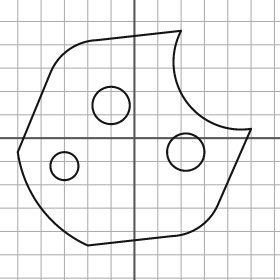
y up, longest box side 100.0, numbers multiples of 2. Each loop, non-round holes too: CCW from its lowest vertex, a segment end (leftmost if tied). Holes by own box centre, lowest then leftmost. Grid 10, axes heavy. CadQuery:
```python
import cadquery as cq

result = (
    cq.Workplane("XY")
    .moveTo(-20.0, -46.0)
    .lineTo(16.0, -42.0)
    .threePointArc((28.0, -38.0), (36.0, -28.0))
    .lineTo(50.0, 4.0)
    .threePointArc((22.0, 16.0), (20.0, 46.0))
    .lineTo(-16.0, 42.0)
    .threePointArc((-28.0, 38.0), (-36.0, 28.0))
    .lineTo(-50.0, -6.0)
    .threePointArc((-40.0, -30.0), (-20.0, -46.0))
    .close()
    .moveTo(-30.0, -12.0)
    .circle(6.0)
    .moveTo(22.0, -6.0)
    .circle(8.0)
    .moveTo(-10.0, 14.0)
    .circle(8.0)
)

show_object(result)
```